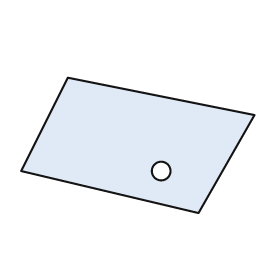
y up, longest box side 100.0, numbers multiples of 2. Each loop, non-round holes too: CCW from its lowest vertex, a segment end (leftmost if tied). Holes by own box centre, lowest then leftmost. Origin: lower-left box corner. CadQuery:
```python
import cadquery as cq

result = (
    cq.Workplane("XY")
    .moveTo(76.0, 0.0)
    .lineTo(100.0, 42.0)
    .lineTo(20.0, 58.0)
    .lineTo(0.0, 18.0)
    .close()
    .moveTo(60.0, 18.0)
    .circle(4.0)
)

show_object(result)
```